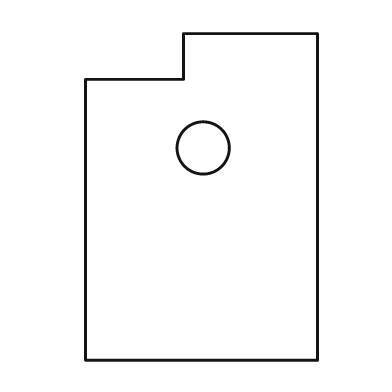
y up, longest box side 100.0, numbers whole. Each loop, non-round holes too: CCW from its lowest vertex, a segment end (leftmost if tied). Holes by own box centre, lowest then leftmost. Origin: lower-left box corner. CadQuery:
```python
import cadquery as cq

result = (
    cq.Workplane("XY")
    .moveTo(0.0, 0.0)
    .lineTo(71.0, 0.0)
    .lineTo(71.0, 100.0)
    .lineTo(30.0, 100.0)
    .lineTo(30.0, 86.0)
    .lineTo(0.0, 86.0)
    .close()
    .moveTo(36.0, 65.0)
    .circle(8.0)
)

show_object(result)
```